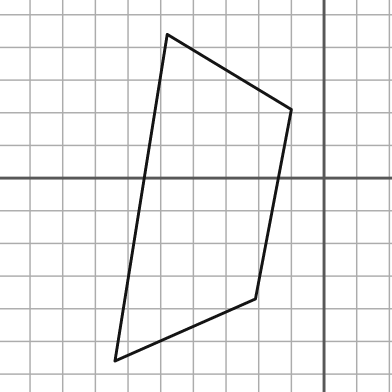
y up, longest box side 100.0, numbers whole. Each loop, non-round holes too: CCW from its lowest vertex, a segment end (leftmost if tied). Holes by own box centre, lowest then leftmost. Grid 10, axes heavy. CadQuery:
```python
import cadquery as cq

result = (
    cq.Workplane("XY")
    .moveTo(-64.0, -56.0)
    .lineTo(-21.0, -37.0)
    .lineTo(-10.0, 21.0)
    .lineTo(-48.0, 44.0)
    .close()
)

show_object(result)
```